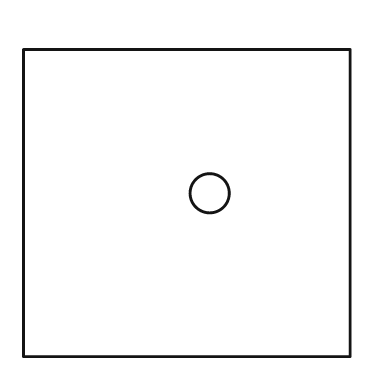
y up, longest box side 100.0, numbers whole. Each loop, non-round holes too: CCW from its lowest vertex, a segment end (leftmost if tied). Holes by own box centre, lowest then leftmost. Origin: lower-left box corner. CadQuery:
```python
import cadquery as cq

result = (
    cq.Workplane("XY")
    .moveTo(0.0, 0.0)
    .lineTo(100.0, 0.0)
    .lineTo(100.0, 94.0)
    .lineTo(0.0, 94.0)
    .close()
    .moveTo(57.0, 50.0)
    .circle(6.0)
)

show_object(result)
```